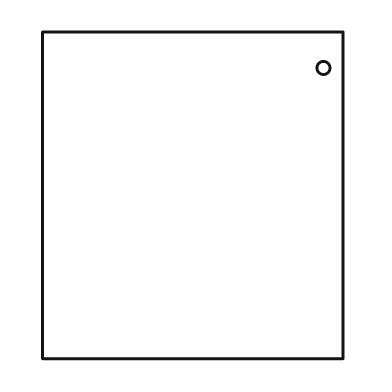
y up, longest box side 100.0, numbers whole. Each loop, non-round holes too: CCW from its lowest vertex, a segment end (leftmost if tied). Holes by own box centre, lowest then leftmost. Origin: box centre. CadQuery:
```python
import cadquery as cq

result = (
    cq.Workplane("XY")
    .moveTo(-46.0, -50.0)
    .lineTo(46.0, -50.0)
    .lineTo(46.0, 50.0)
    .lineTo(-46.0, 50.0)
    .close()
    .moveTo(40.0, 39.0)
    .circle(2.0)
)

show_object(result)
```